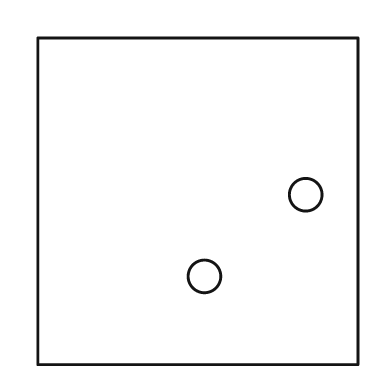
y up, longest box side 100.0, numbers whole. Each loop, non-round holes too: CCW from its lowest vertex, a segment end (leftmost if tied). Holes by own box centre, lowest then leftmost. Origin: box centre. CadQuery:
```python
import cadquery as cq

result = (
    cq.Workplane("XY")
    .moveTo(-49.0, -50.0)
    .lineTo(49.0, -50.0)
    .lineTo(49.0, 50.0)
    .lineTo(-49.0, 50.0)
    .close()
    .moveTo(2.0, -23.0)
    .circle(5.0)
    .moveTo(33.0, 2.0)
    .circle(5.0)
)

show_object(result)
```